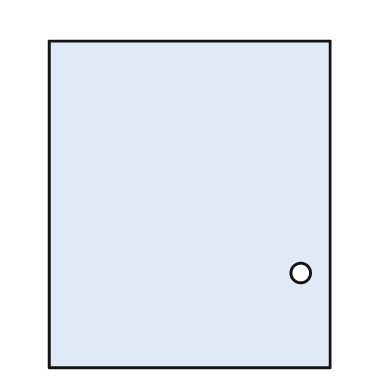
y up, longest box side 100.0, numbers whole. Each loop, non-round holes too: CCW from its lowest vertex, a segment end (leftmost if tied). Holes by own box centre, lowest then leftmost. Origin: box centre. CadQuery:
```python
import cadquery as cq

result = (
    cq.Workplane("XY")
    .moveTo(-43.0, -50.0)
    .lineTo(43.0, -50.0)
    .lineTo(43.0, 50.0)
    .lineTo(-43.0, 50.0)
    .close()
    .moveTo(34.0, -21.0)
    .circle(3.0)
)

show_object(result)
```